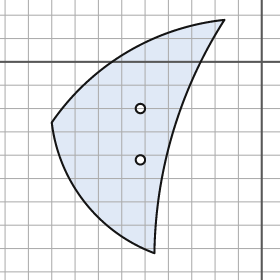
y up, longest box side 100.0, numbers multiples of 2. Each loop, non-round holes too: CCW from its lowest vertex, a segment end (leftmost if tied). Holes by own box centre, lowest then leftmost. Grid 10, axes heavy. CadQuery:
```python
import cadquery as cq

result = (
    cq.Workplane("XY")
    .moveTo(-46.0, -82.0)
    .threePointArc((-38.0, -30.0), (-16.0, 18.0))
    .threePointArc((-58.0, 4.0), (-90.0, -26.0))
    .threePointArc((-76.0, -60.0), (-46.0, -82.0))
    .close()
    .moveTo(-52.0, -42.0)
    .circle(2.0)
    .moveTo(-52.0, -20.0)
    .circle(2.0)
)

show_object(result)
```